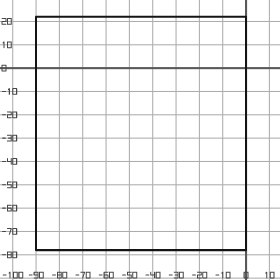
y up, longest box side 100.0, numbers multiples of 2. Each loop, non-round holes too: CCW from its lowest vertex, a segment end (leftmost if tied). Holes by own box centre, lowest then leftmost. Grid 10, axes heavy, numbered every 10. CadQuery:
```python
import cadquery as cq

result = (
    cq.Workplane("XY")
    .moveTo(-90.0, -78.0)
    .lineTo(0.0, -78.0)
    .lineTo(0.0, 22.0)
    .lineTo(-90.0, 22.0)
    .close()
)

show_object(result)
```